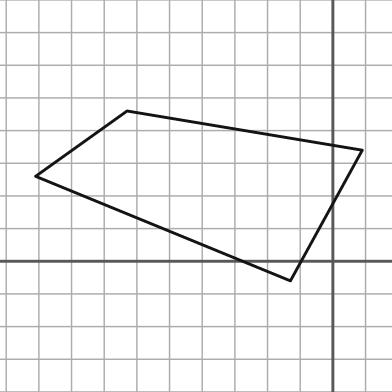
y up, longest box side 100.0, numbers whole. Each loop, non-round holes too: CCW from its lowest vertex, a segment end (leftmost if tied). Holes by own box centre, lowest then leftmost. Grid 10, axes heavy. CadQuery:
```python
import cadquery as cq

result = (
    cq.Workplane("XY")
    .moveTo(-13.0, -6.0)
    .lineTo(9.0, 34.0)
    .lineTo(-63.0, 46.0)
    .lineTo(-91.0, 26.0)
    .close()
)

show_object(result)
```